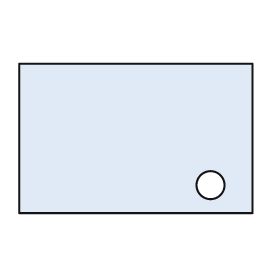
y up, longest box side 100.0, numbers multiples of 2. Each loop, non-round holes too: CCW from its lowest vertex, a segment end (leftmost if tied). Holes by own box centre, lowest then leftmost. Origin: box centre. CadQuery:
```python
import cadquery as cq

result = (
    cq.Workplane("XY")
    .moveTo(-50.0, -32.0)
    .lineTo(50.0, -32.0)
    .lineTo(50.0, 32.0)
    .lineTo(-50.0, 32.0)
    .close()
    .moveTo(32.0, -20.0)
    .circle(6.0)
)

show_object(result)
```